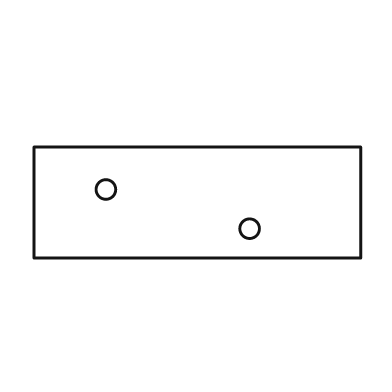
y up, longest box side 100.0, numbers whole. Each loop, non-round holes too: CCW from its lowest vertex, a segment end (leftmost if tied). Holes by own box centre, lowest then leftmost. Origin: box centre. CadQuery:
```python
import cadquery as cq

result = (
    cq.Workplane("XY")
    .moveTo(-50.0, -17.0)
    .lineTo(50.0, -17.0)
    .lineTo(50.0, 17.0)
    .lineTo(-50.0, 17.0)
    .close()
    .moveTo(16.0, -8.0)
    .circle(3.0)
    .moveTo(-28.0, 4.0)
    .circle(3.0)
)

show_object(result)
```